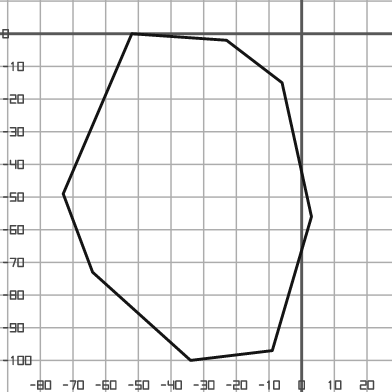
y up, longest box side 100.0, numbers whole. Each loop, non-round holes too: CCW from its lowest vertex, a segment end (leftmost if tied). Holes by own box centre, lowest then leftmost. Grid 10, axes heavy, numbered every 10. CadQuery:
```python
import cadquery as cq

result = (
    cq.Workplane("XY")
    .moveTo(-34.0, -100.0)
    .lineTo(-9.0, -97.0)
    .lineTo(3.0, -56.0)
    .lineTo(-6.0, -15.0)
    .lineTo(-23.0, -2.0)
    .lineTo(-52.0, 0.0)
    .lineTo(-73.0, -49.0)
    .lineTo(-64.0, -73.0)
    .close()
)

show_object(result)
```